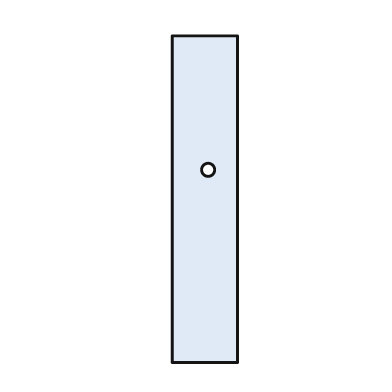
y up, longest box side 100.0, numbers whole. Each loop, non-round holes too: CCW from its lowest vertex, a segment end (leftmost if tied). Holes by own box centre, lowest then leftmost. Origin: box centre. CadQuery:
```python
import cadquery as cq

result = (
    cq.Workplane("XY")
    .moveTo(-10.0, -50.0)
    .lineTo(10.0, -50.0)
    .lineTo(10.0, 50.0)
    .lineTo(-10.0, 50.0)
    .close()
    .moveTo(1.0, 9.0)
    .circle(2.0)
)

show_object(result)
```